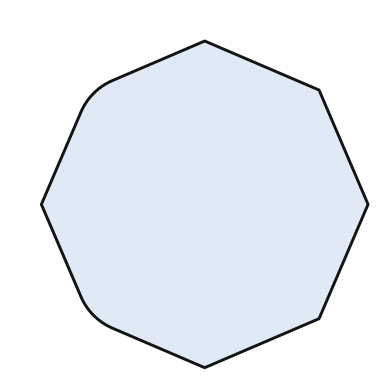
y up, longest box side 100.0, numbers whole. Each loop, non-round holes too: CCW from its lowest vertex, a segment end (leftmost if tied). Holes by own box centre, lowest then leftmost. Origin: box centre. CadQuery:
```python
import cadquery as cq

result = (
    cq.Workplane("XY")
    .moveTo(0.0, -50.0)
    .lineTo(35.0, -35.0)
    .lineTo(50.0, 0.0)
    .lineTo(35.0, 35.0)
    .lineTo(0.0, 50.0)
    .lineTo(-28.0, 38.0)
    .threePointArc((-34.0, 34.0), (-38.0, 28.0))
    .lineTo(-50.0, 0.0)
    .lineTo(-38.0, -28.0)
    .threePointArc((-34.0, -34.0), (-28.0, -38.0))
    .close()
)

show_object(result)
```